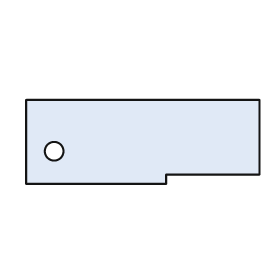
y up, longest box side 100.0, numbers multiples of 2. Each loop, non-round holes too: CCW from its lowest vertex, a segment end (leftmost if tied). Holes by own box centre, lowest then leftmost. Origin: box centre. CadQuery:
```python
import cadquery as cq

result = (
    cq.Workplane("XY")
    .moveTo(-50.0, -18.0)
    .lineTo(10.0, -18.0)
    .lineTo(10.0, -14.0)
    .lineTo(50.0, -14.0)
    .lineTo(50.0, 18.0)
    .lineTo(-50.0, 18.0)
    .close()
    .moveTo(-38.0, -4.0)
    .circle(4.0)
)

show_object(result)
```